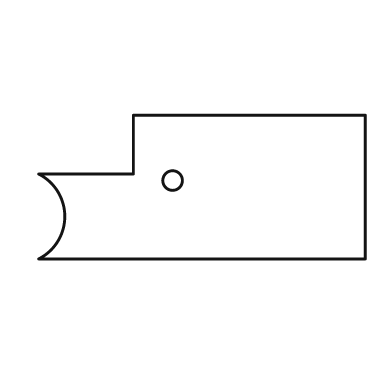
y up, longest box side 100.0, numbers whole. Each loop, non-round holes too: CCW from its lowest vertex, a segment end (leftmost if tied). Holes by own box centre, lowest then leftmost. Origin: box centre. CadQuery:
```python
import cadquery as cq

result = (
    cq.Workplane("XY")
    .moveTo(-50.0, -22.0)
    .lineTo(50.0, -22.0)
    .lineTo(50.0, 22.0)
    .lineTo(-21.0, 22.0)
    .lineTo(-21.0, 4.0)
    .lineTo(-50.0, 4.0)
    .threePointArc((-42.0, -9.0), (-50.0, -22.0))
    .close()
    .moveTo(-9.0, 2.0)
    .circle(3.0)
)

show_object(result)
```